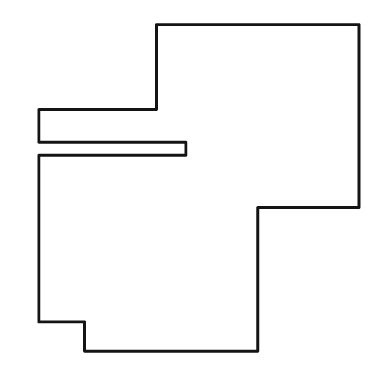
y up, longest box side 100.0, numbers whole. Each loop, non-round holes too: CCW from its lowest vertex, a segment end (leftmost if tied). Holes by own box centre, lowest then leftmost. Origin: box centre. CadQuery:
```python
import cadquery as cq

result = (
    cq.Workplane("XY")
    .moveTo(-35.0, -50.0)
    .lineTo(18.0, -50.0)
    .lineTo(18.0, -6.0)
    .lineTo(49.0, -6.0)
    .lineTo(49.0, 50.0)
    .lineTo(-13.0, 50.0)
    .lineTo(-13.0, 24.0)
    .lineTo(-49.0, 24.0)
    .lineTo(-49.0, 14.0)
    .lineTo(-4.0, 14.0)
    .lineTo(-4.0, 10.0)
    .lineTo(-49.0, 10.0)
    .lineTo(-49.0, -41.0)
    .lineTo(-35.0, -41.0)
    .close()
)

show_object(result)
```